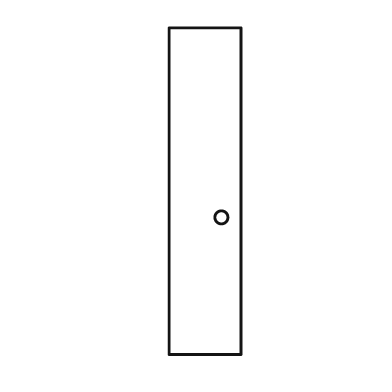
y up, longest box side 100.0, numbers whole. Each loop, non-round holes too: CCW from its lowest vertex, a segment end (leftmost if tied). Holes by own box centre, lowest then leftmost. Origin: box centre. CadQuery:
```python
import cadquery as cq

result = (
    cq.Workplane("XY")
    .moveTo(-11.0, -50.0)
    .lineTo(11.0, -50.0)
    .lineTo(11.0, 50.0)
    .lineTo(-11.0, 50.0)
    .close()
    .moveTo(5.0, -8.0)
    .circle(2.0)
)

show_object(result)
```